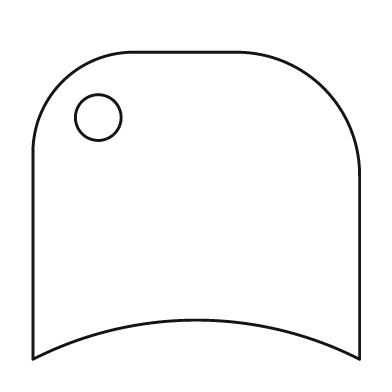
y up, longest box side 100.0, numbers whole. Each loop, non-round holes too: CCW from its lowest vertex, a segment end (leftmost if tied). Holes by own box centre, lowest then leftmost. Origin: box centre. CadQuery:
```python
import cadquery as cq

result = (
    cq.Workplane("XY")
    .moveTo(-50.0, -47.0)
    .threePointArc((0.0, -35.0), (50.0, -47.0))
    .lineTo(50.0, 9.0)
    .threePointArc((39.0, 36.0), (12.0, 47.0))
    .lineTo(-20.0, 47.0)
    .threePointArc((-41.0, 38.0), (-50.0, 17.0))
    .close()
    .moveTo(-30.0, 27.0)
    .circle(7.0)
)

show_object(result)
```